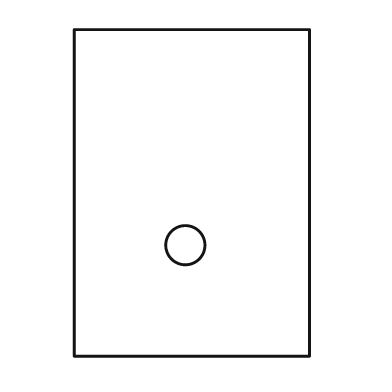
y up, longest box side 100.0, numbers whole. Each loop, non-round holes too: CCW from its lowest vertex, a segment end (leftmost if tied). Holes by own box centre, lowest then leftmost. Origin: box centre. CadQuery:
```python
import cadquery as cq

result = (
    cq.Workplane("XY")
    .moveTo(-36.0, -50.0)
    .lineTo(36.0, -50.0)
    .lineTo(36.0, 50.0)
    .lineTo(-36.0, 50.0)
    .close()
    .moveTo(-2.0, -16.0)
    .circle(6.0)
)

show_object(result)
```